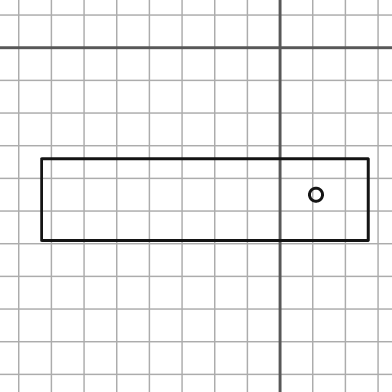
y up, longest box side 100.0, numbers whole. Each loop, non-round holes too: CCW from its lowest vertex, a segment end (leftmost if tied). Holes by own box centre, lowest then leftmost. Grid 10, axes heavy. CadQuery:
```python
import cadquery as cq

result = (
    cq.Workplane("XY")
    .moveTo(-73.0, -59.0)
    .lineTo(27.0, -59.0)
    .lineTo(27.0, -34.0)
    .lineTo(-73.0, -34.0)
    .close()
    .moveTo(11.0, -45.0)
    .circle(2.0)
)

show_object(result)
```